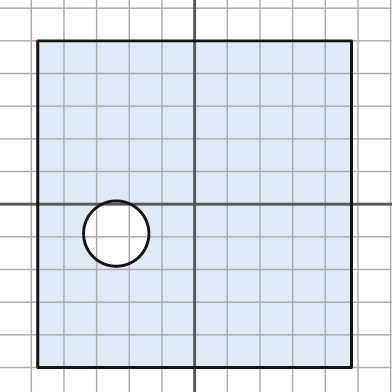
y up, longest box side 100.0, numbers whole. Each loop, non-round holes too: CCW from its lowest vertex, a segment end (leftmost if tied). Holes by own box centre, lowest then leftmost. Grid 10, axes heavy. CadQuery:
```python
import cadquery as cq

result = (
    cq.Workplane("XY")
    .moveTo(-48.0, -50.0)
    .lineTo(48.0, -50.0)
    .lineTo(48.0, 50.0)
    .lineTo(-48.0, 50.0)
    .close()
    .moveTo(-24.0, -9.0)
    .circle(10.0)
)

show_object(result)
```